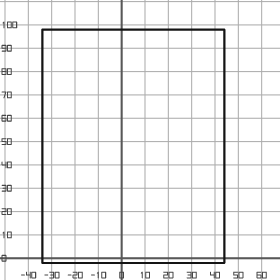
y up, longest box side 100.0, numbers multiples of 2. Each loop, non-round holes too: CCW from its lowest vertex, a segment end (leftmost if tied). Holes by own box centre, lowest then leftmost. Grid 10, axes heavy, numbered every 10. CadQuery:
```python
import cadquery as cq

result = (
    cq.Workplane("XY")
    .moveTo(-34.0, -2.0)
    .lineTo(44.0, -2.0)
    .lineTo(44.0, 98.0)
    .lineTo(-34.0, 98.0)
    .close()
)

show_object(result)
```